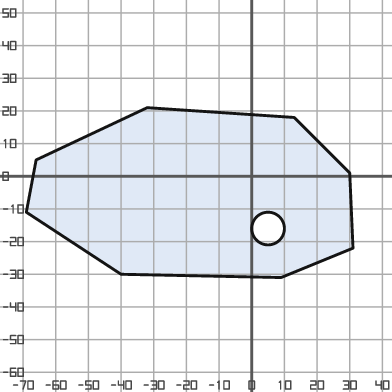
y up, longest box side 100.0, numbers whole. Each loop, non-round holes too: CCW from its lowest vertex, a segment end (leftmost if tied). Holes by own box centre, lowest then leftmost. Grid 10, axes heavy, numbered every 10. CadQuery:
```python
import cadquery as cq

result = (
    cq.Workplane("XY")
    .moveTo(9.0, -31.0)
    .lineTo(31.0, -22.0)
    .lineTo(30.0, 1.0)
    .lineTo(13.0, 18.0)
    .lineTo(-32.0, 21.0)
    .lineTo(-66.0, 5.0)
    .lineTo(-69.0, -11.0)
    .lineTo(-40.0, -30.0)
    .close()
    .moveTo(5.0, -16.0)
    .circle(5.0)
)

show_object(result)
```